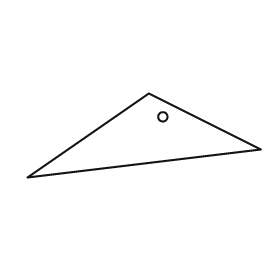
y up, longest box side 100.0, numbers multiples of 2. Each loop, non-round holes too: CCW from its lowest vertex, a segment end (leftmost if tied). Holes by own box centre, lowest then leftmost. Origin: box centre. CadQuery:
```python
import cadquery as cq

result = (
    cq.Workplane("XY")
    .moveTo(-50.0, -18.0)
    .lineTo(50.0, -6.0)
    .lineTo(2.0, 18.0)
    .close()
    .moveTo(8.0, 8.0)
    .circle(2.0)
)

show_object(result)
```